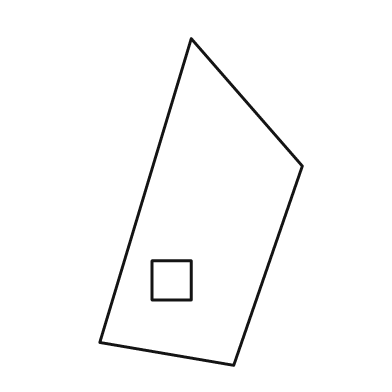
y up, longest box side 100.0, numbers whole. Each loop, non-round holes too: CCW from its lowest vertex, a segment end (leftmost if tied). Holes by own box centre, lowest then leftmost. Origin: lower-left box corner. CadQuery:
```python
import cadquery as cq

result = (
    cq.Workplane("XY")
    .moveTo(41.0, 0.0)
    .lineTo(62.0, 61.0)
    .lineTo(28.0, 100.0)
    .lineTo(0.0, 7.0)
    .close()
    .moveTo(16.0, 20.0)
    .lineTo(28.0, 20.0)
    .lineTo(28.0, 32.0)
    .lineTo(16.0, 32.0)
    .close()
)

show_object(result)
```